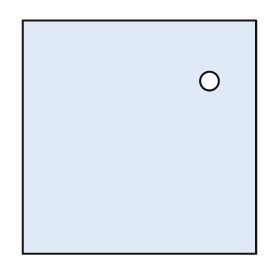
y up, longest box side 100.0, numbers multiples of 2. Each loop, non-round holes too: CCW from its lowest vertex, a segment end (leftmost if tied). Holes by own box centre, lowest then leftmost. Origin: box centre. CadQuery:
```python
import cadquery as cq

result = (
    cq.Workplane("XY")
    .moveTo(-50.0, -50.0)
    .lineTo(50.0, -50.0)
    .lineTo(50.0, 50.0)
    .lineTo(-50.0, 50.0)
    .close()
    .moveTo(30.0, 24.0)
    .circle(4.0)
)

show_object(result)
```